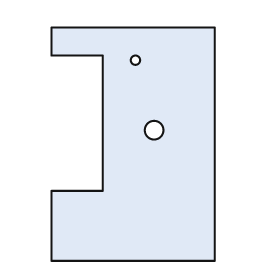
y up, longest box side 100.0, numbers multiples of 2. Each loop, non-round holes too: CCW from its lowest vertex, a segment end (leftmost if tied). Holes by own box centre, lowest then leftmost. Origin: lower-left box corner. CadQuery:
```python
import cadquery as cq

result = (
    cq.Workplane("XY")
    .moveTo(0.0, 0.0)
    .lineTo(70.0, 0.0)
    .lineTo(70.0, 100.0)
    .lineTo(0.0, 100.0)
    .lineTo(0.0, 88.0)
    .lineTo(22.0, 88.0)
    .lineTo(22.0, 30.0)
    .lineTo(0.0, 30.0)
    .close()
    .moveTo(44.0, 56.0)
    .circle(4.0)
    .moveTo(36.0, 86.0)
    .circle(2.0)
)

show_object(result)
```